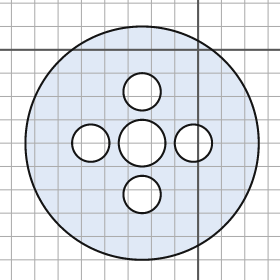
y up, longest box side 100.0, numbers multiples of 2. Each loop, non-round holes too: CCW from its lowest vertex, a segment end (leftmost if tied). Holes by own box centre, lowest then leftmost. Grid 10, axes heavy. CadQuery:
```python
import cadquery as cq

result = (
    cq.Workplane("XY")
    .moveTo(-24.0, -40.0)
    .circle(50.0)
    .moveTo(-24.0, -62.0)
    .circle(8.0)
    .moveTo(-46.0, -40.0)
    .circle(8.0)
    .moveTo(-24.0, -40.0)
    .circle(10.0)
    .moveTo(-2.0, -40.0)
    .circle(8.0)
    .moveTo(-24.0, -18.0)
    .circle(8.0)
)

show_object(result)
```